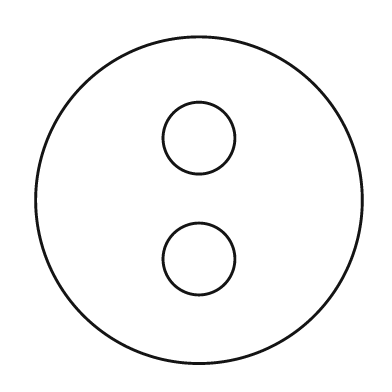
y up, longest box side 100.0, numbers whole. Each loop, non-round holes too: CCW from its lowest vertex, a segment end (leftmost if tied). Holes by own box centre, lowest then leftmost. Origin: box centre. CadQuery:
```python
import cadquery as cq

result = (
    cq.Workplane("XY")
    .moveTo(0.0, 0.0)
    .circle(50.0)
    .moveTo(0.0, -18.0)
    .circle(11.0)
    .moveTo(0.0, 19.0)
    .circle(11.0)
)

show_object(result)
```